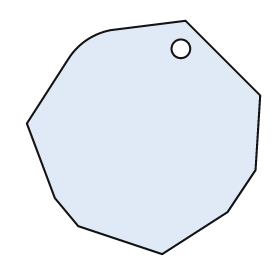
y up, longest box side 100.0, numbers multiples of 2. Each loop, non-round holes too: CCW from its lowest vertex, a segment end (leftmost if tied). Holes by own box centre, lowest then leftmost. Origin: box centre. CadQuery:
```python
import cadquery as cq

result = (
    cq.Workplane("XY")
    .moveTo(8.0, -50.0)
    .lineTo(36.0, -32.0)
    .lineTo(48.0, -14.0)
    .lineTo(50.0, 18.0)
    .lineTo(18.0, 50.0)
    .lineTo(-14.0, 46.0)
    .threePointArc((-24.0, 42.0), (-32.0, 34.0))
    .lineTo(-50.0, 6.0)
    .lineTo(-38.0, -26.0)
    .lineTo(-28.0, -38.0)
    .close()
    .moveTo(16.0, 38.0)
    .circle(4.0)
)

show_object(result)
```